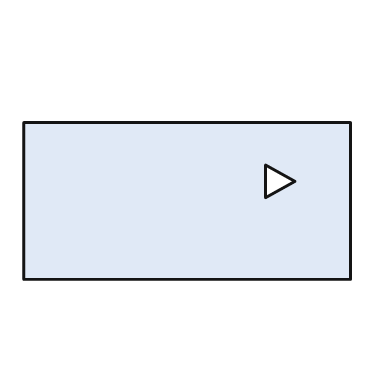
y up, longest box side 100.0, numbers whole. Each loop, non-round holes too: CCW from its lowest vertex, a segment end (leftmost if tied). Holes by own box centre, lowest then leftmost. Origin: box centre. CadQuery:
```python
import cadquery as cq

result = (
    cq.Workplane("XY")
    .moveTo(-50.0, -24.0)
    .lineTo(50.0, -24.0)
    .lineTo(50.0, 24.0)
    .lineTo(-50.0, 24.0)
    .close()
    .moveTo(24.0, 1.0)
    .lineTo(33.0, 6.0)
    .lineTo(24.0, 11.0)
    .close()
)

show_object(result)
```